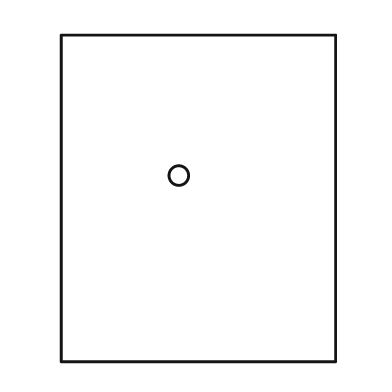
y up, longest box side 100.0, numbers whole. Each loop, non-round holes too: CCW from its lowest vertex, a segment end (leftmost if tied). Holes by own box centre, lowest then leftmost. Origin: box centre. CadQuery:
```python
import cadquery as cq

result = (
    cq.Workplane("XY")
    .moveTo(-42.0, -50.0)
    .lineTo(42.0, -50.0)
    .lineTo(42.0, 50.0)
    .lineTo(-42.0, 50.0)
    .close()
    .moveTo(-6.0, 7.0)
    .circle(3.0)
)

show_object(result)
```